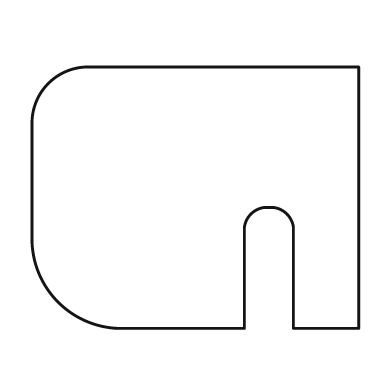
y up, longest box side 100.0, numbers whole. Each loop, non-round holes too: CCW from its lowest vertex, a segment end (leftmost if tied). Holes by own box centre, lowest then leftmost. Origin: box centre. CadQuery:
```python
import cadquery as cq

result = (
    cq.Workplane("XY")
    .moveTo(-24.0, -40.0)
    .lineTo(15.0, -40.0)
    .lineTo(15.0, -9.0)
    .threePointArc((17.0, -5.0), (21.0, -3.0))
    .lineTo(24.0, -3.0)
    .threePointArc((28.0, -5.0), (30.0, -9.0))
    .lineTo(30.0, -40.0)
    .lineTo(50.0, -40.0)
    .lineTo(50.0, 40.0)
    .lineTo(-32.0, 40.0)
    .threePointArc((-45.0, 35.0), (-50.0, 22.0))
    .lineTo(-50.0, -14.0)
    .threePointArc((-42.0, -32.0), (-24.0, -40.0))
    .close()
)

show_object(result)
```